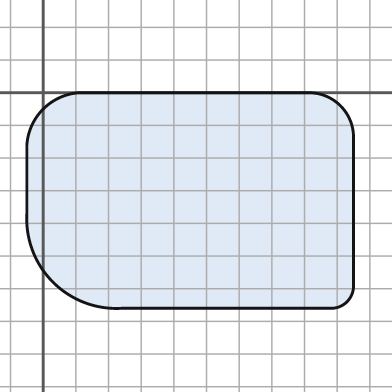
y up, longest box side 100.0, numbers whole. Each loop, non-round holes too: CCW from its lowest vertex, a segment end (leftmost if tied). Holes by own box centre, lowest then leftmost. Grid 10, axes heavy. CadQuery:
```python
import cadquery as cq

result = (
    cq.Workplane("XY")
    .moveTo(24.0, -66.0)
    .lineTo(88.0, -66.0)
    .threePointArc((93.0, -64.0), (95.0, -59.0))
    .lineTo(95.0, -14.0)
    .threePointArc((91.0, -4.0), (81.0, 0.0))
    .lineTo(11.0, 0.0)
    .threePointArc((0.0, -5.0), (-5.0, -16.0))
    .lineTo(-5.0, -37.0)
    .threePointArc((3.0, -58.0), (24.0, -66.0))
    .close()
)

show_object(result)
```